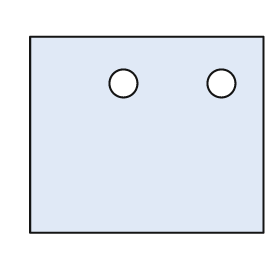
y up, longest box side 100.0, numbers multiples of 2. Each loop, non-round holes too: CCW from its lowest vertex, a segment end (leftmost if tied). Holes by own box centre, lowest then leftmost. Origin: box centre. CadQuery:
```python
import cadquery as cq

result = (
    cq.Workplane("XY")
    .moveTo(-50.0, -42.0)
    .lineTo(50.0, -42.0)
    .lineTo(50.0, 42.0)
    .lineTo(-50.0, 42.0)
    .close()
    .moveTo(-10.0, 22.0)
    .circle(6.0)
    .moveTo(32.0, 22.0)
    .circle(6.0)
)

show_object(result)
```